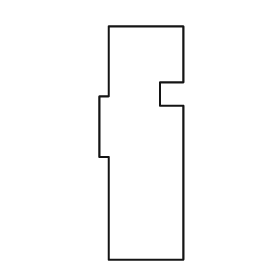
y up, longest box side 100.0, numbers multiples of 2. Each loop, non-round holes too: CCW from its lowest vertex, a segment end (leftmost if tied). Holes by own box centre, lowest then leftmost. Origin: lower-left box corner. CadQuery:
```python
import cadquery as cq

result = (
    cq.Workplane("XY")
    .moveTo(4.0, 0.0)
    .lineTo(36.0, 0.0)
    .lineTo(36.0, 66.0)
    .lineTo(26.0, 66.0)
    .lineTo(26.0, 76.0)
    .lineTo(36.0, 76.0)
    .lineTo(36.0, 100.0)
    .lineTo(4.0, 100.0)
    .lineTo(4.0, 70.0)
    .lineTo(0.0, 70.0)
    .lineTo(0.0, 44.0)
    .lineTo(4.0, 44.0)
    .close()
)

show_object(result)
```